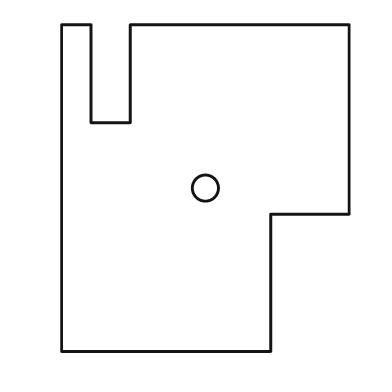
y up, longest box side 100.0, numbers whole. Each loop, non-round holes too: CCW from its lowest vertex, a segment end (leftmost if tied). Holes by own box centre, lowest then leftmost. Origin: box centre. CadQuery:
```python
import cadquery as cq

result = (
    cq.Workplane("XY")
    .moveTo(-44.0, -50.0)
    .lineTo(20.0, -50.0)
    .lineTo(20.0, -8.0)
    .lineTo(44.0, -8.0)
    .lineTo(44.0, 50.0)
    .lineTo(-23.0, 50.0)
    .lineTo(-23.0, 20.0)
    .lineTo(-35.0, 20.0)
    .lineTo(-35.0, 50.0)
    .lineTo(-44.0, 50.0)
    .close()
    .moveTo(0.0, 0.0)
    .circle(4.0)
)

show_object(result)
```